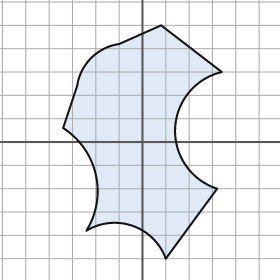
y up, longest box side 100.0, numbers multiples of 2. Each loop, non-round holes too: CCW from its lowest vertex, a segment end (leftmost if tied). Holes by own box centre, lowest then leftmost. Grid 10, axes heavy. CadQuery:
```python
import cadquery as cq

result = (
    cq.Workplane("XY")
    .moveTo(10.0, -50.0)
    .lineTo(32.0, -20.0)
    .threePointArc((14.0, 6.0), (34.0, 30.0))
    .lineTo(8.0, 50.0)
    .lineTo(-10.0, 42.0)
    .threePointArc((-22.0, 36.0), (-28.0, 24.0))
    .lineTo(-34.0, 6.0)
    .threePointArc((-20.0, -14.0), (-24.0, -38.0))
    .threePointArc((-4.0, -36.0), (10.0, -50.0))
    .close()
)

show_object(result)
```